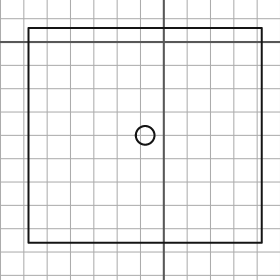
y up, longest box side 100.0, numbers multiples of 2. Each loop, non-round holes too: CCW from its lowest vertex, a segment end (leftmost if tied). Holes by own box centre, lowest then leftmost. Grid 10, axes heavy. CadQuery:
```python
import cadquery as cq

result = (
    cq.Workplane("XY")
    .moveTo(-58.0, -86.0)
    .lineTo(42.0, -86.0)
    .lineTo(42.0, 6.0)
    .lineTo(-58.0, 6.0)
    .close()
    .moveTo(-8.0, -40.0)
    .circle(4.0)
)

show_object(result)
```